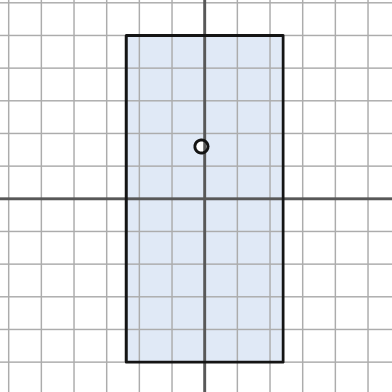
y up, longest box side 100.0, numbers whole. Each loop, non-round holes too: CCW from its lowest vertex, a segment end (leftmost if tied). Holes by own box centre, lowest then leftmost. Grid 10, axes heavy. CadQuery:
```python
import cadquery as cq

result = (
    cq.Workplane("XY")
    .moveTo(-24.0, -50.0)
    .lineTo(24.0, -50.0)
    .lineTo(24.0, 50.0)
    .lineTo(-24.0, 50.0)
    .close()
    .moveTo(-1.0, 16.0)
    .circle(2.0)
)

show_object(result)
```